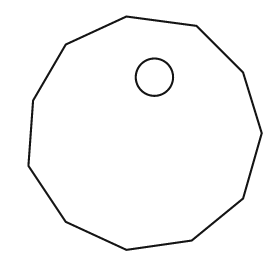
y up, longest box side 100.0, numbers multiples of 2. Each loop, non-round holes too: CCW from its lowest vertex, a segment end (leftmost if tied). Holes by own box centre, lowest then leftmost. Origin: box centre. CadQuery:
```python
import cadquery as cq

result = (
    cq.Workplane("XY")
    .moveTo(-8.0, -50.0)
    .lineTo(20.0, -46.0)
    .lineTo(42.0, -28.0)
    .lineTo(50.0, 0.0)
    .lineTo(42.0, 26.0)
    .lineTo(22.0, 46.0)
    .lineTo(-8.0, 50.0)
    .lineTo(-34.0, 38.0)
    .lineTo(-48.0, 14.0)
    .lineTo(-50.0, -14.0)
    .lineTo(-34.0, -38.0)
    .close()
    .moveTo(4.0, 24.0)
    .circle(8.0)
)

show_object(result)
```